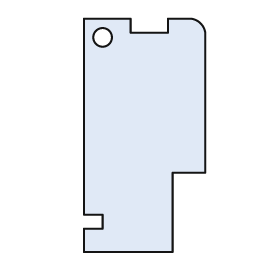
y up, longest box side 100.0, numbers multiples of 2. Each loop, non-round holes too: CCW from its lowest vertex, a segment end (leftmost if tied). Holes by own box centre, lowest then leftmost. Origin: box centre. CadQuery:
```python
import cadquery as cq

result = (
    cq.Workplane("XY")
    .moveTo(-26.0, -50.0)
    .lineTo(12.0, -50.0)
    .lineTo(12.0, -16.0)
    .lineTo(26.0, -16.0)
    .lineTo(26.0, 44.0)
    .threePointArc((24.0, 48.0), (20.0, 50.0))
    .lineTo(10.0, 50.0)
    .lineTo(10.0, 44.0)
    .lineTo(-6.0, 44.0)
    .lineTo(-6.0, 50.0)
    .lineTo(-26.0, 50.0)
    .lineTo(-26.0, -34.0)
    .lineTo(-18.0, -34.0)
    .lineTo(-18.0, -40.0)
    .lineTo(-26.0, -40.0)
    .close()
    .moveTo(-18.0, 42.0)
    .circle(4.0)
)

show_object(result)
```